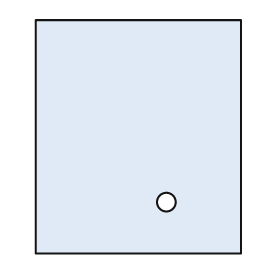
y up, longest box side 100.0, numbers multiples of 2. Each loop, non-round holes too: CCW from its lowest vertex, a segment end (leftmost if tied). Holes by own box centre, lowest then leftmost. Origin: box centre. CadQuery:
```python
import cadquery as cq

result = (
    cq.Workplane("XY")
    .moveTo(-44.0, -50.0)
    .lineTo(44.0, -50.0)
    .lineTo(44.0, 50.0)
    .lineTo(-44.0, 50.0)
    .close()
    .moveTo(12.0, -28.0)
    .circle(4.0)
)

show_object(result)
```